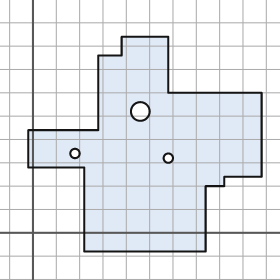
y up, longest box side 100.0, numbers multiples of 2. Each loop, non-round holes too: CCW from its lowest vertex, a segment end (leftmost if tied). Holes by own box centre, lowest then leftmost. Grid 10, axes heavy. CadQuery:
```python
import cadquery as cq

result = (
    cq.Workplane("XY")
    .moveTo(22.0, -8.0)
    .lineTo(74.0, -8.0)
    .lineTo(74.0, 20.0)
    .lineTo(82.0, 20.0)
    .lineTo(82.0, 24.0)
    .lineTo(98.0, 24.0)
    .lineTo(98.0, 60.0)
    .lineTo(58.0, 60.0)
    .lineTo(58.0, 84.0)
    .lineTo(38.0, 84.0)
    .lineTo(38.0, 76.0)
    .lineTo(28.0, 76.0)
    .lineTo(28.0, 44.0)
    .lineTo(-2.0, 44.0)
    .lineTo(-2.0, 28.0)
    .lineTo(22.0, 28.0)
    .close()
    .moveTo(58.0, 32.0)
    .circle(2.0)
    .moveTo(18.0, 34.0)
    .circle(2.0)
    .moveTo(46.0, 52.0)
    .circle(4.0)
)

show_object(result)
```